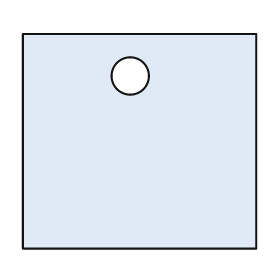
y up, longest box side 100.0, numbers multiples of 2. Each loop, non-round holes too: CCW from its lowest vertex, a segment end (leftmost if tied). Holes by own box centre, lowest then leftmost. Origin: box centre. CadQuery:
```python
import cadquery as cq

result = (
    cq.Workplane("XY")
    .moveTo(-50.0, -46.0)
    .lineTo(50.0, -46.0)
    .lineTo(50.0, 46.0)
    .lineTo(-50.0, 46.0)
    .close()
    .moveTo(-4.0, 28.0)
    .circle(8.0)
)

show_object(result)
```